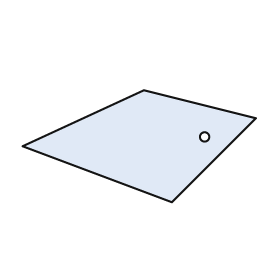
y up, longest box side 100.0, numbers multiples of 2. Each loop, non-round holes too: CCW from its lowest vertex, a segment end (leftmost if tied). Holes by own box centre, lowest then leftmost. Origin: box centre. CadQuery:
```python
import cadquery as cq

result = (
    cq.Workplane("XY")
    .moveTo(14.0, -24.0)
    .lineTo(50.0, 12.0)
    .lineTo(2.0, 24.0)
    .lineTo(-50.0, 0.0)
    .close()
    .moveTo(28.0, 4.0)
    .circle(2.0)
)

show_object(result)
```